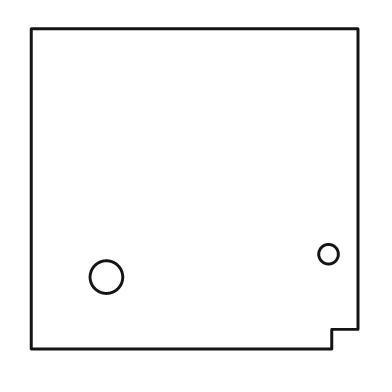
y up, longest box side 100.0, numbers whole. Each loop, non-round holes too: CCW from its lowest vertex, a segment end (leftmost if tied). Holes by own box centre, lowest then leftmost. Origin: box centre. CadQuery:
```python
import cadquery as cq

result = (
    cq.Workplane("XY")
    .moveTo(-50.0, -49.0)
    .lineTo(42.0, -49.0)
    .lineTo(42.0, -43.0)
    .lineTo(50.0, -43.0)
    .lineTo(50.0, 49.0)
    .lineTo(-50.0, 49.0)
    .close()
    .moveTo(-27.0, -27.0)
    .circle(5.0)
    .moveTo(41.0, -20.0)
    .circle(3.0)
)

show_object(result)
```